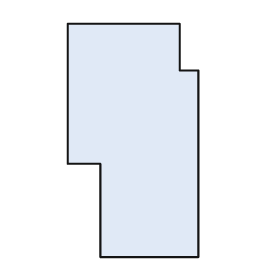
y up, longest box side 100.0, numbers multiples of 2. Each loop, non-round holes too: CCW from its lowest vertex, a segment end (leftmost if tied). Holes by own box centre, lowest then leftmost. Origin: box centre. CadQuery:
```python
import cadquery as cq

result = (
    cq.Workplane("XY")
    .moveTo(-14.0, -50.0)
    .lineTo(28.0, -50.0)
    .lineTo(28.0, 30.0)
    .lineTo(20.0, 30.0)
    .lineTo(20.0, 50.0)
    .lineTo(-28.0, 50.0)
    .lineTo(-28.0, -10.0)
    .lineTo(-14.0, -10.0)
    .close()
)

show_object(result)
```